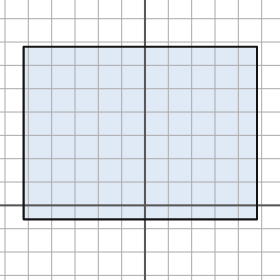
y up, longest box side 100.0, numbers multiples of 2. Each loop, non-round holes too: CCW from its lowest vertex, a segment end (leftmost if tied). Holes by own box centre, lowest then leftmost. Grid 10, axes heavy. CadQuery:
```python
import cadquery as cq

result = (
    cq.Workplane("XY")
    .moveTo(-52.0, -6.0)
    .lineTo(48.0, -6.0)
    .lineTo(48.0, 68.0)
    .lineTo(-52.0, 68.0)
    .close()
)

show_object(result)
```